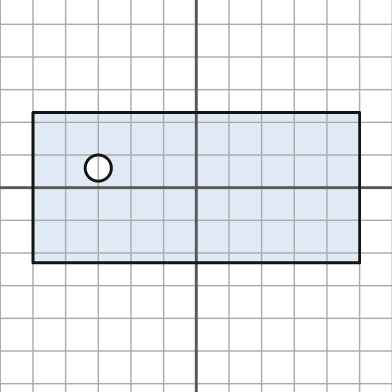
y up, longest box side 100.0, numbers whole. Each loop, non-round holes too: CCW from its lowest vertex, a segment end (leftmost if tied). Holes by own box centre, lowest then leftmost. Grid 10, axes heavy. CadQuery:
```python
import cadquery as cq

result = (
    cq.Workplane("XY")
    .moveTo(-50.0, -23.0)
    .lineTo(50.0, -23.0)
    .lineTo(50.0, 23.0)
    .lineTo(-50.0, 23.0)
    .close()
    .moveTo(-30.0, 6.0)
    .circle(4.0)
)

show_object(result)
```